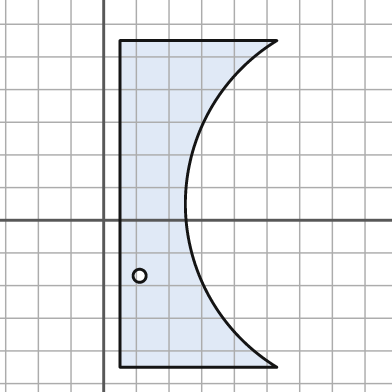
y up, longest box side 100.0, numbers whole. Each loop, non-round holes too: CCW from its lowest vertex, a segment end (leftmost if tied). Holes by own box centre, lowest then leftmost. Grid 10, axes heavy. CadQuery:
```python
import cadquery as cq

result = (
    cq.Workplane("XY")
    .moveTo(5.0, -45.0)
    .lineTo(53.0, -45.0)
    .threePointArc((25.0, 5.0), (53.0, 55.0))
    .lineTo(5.0, 55.0)
    .close()
    .moveTo(11.0, -17.0)
    .circle(2.0)
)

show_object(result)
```